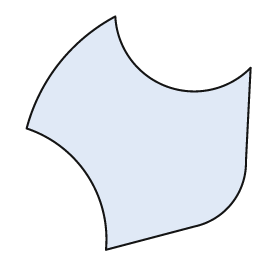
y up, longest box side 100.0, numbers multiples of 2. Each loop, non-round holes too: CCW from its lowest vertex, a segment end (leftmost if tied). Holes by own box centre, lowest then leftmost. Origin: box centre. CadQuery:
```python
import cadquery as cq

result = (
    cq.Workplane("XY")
    .moveTo(-14.0, -50.0)
    .lineTo(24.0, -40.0)
    .threePointArc((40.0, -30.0), (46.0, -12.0))
    .lineTo(48.0, 28.0)
    .threePointArc((12.0, 20.0), (-10.0, 50.0))
    .threePointArc((-34.0, 30.0), (-48.0, 2.0))
    .threePointArc((-22.0, -18.0), (-14.0, -50.0))
    .close()
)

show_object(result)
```